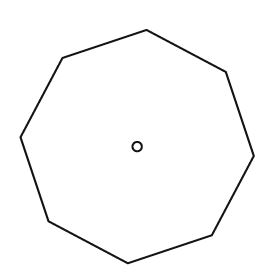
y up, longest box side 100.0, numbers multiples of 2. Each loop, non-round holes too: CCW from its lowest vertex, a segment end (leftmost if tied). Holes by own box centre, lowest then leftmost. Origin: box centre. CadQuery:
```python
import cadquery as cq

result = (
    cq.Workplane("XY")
    .moveTo(-4.0, -50.0)
    .lineTo(32.0, -38.0)
    .lineTo(50.0, -4.0)
    .lineTo(38.0, 32.0)
    .lineTo(4.0, 50.0)
    .lineTo(-32.0, 38.0)
    .lineTo(-50.0, 4.0)
    .lineTo(-38.0, -32.0)
    .close()
    .moveTo(0.0, 0.0)
    .circle(2.0)
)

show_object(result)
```